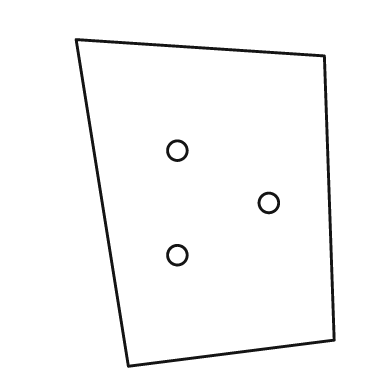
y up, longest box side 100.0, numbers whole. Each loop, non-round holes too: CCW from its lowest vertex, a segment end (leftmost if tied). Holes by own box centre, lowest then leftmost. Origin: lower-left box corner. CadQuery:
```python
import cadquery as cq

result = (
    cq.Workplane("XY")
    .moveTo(16.0, 0.0)
    .lineTo(79.0, 8.0)
    .lineTo(76.0, 95.0)
    .lineTo(0.0, 100.0)
    .close()
    .moveTo(31.0, 34.0)
    .circle(3.0)
    .moveTo(59.0, 50.0)
    .circle(3.0)
    .moveTo(31.0, 66.0)
    .circle(3.0)
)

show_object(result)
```